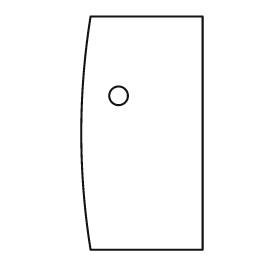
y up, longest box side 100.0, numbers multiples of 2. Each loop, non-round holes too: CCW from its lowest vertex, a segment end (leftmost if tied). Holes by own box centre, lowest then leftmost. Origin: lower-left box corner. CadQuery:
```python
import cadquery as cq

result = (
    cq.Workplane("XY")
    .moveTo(4.0, 0.0)
    .lineTo(52.0, 0.0)
    .lineTo(52.0, 100.0)
    .lineTo(4.0, 100.0)
    .threePointArc((0.0, 50.0), (4.0, 0.0))
    .close()
    .moveTo(16.0, 66.0)
    .circle(4.0)
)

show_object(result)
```